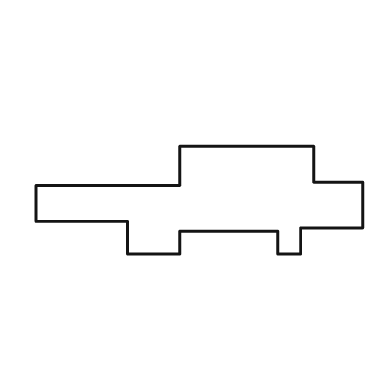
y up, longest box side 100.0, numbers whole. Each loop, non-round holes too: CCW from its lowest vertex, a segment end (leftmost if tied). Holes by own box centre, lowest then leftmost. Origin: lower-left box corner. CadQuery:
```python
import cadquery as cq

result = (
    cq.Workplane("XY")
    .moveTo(28.0, 0.0)
    .lineTo(44.0, 0.0)
    .lineTo(44.0, 7.0)
    .lineTo(74.0, 7.0)
    .lineTo(74.0, 0.0)
    .lineTo(81.0, 0.0)
    .lineTo(81.0, 8.0)
    .lineTo(100.0, 8.0)
    .lineTo(100.0, 22.0)
    .lineTo(85.0, 22.0)
    .lineTo(85.0, 33.0)
    .lineTo(44.0, 33.0)
    .lineTo(44.0, 21.0)
    .lineTo(0.0, 21.0)
    .lineTo(0.0, 10.0)
    .lineTo(28.0, 10.0)
    .close()
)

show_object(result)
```